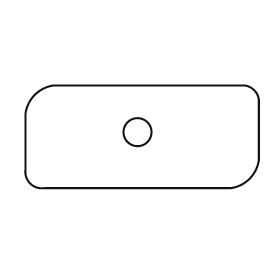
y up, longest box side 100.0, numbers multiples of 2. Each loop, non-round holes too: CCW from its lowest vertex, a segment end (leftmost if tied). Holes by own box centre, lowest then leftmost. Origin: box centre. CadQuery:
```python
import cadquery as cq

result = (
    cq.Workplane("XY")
    .moveTo(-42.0, -22.0)
    .lineTo(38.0, -22.0)
    .threePointArc((46.0, -18.0), (50.0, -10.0))
    .lineTo(50.0, 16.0)
    .threePointArc((48.0, 20.0), (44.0, 22.0))
    .lineTo(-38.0, 22.0)
    .threePointArc((-46.0, 18.0), (-50.0, 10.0))
    .lineTo(-50.0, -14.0)
    .threePointArc((-48.0, -20.0), (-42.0, -22.0))
    .close()
    .moveTo(-2.0, 2.0)
    .circle(6.0)
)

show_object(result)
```